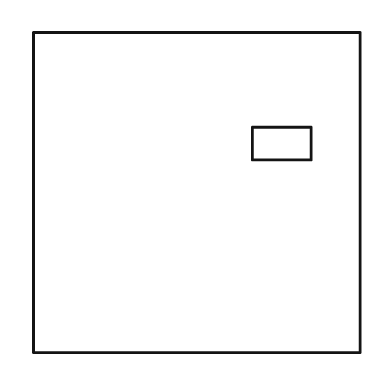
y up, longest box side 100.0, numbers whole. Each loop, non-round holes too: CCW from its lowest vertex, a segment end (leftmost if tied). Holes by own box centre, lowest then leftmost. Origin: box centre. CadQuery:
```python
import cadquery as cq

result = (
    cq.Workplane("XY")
    .moveTo(-50.0, -49.0)
    .lineTo(50.0, -49.0)
    .lineTo(50.0, 49.0)
    .lineTo(-50.0, 49.0)
    .close()
    .moveTo(17.0, 10.0)
    .lineTo(35.0, 10.0)
    .lineTo(35.0, 20.0)
    .lineTo(17.0, 20.0)
    .close()
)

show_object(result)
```